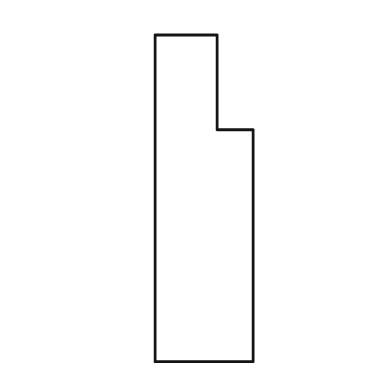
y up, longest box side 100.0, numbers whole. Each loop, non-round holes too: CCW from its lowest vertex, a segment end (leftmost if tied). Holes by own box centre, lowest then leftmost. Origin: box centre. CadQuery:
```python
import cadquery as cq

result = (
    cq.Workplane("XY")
    .moveTo(-15.0, -50.0)
    .lineTo(15.0, -50.0)
    .lineTo(15.0, 21.0)
    .lineTo(4.0, 21.0)
    .lineTo(4.0, 50.0)
    .lineTo(-15.0, 50.0)
    .close()
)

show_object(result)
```